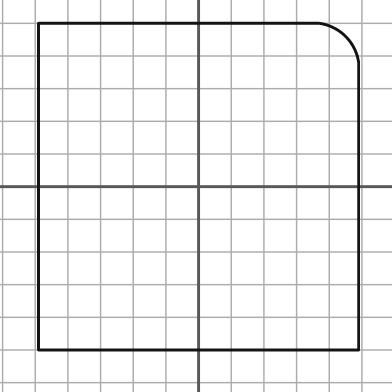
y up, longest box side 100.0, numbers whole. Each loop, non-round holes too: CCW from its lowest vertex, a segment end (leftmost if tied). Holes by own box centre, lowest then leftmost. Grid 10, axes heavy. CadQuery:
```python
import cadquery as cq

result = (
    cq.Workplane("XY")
    .moveTo(-49.0, -50.0)
    .lineTo(49.0, -50.0)
    .lineTo(49.0, 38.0)
    .threePointArc((45.0, 46.0), (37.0, 50.0))
    .lineTo(-49.0, 50.0)
    .close()
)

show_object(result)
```